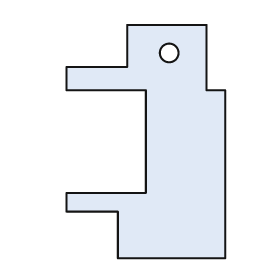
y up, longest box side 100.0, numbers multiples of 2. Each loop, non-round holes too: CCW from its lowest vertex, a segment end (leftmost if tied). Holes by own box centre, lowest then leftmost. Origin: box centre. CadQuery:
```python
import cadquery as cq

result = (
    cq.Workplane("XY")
    .moveTo(-12.0, -50.0)
    .lineTo(34.0, -50.0)
    .lineTo(34.0, 22.0)
    .lineTo(26.0, 22.0)
    .lineTo(26.0, 50.0)
    .lineTo(-8.0, 50.0)
    .lineTo(-8.0, 32.0)
    .lineTo(-34.0, 32.0)
    .lineTo(-34.0, 22.0)
    .lineTo(0.0, 22.0)
    .lineTo(0.0, -22.0)
    .lineTo(-34.0, -22.0)
    .lineTo(-34.0, -30.0)
    .lineTo(-12.0, -30.0)
    .close()
    .moveTo(10.0, 38.0)
    .circle(4.0)
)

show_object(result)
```